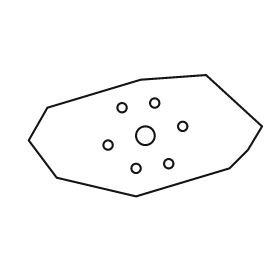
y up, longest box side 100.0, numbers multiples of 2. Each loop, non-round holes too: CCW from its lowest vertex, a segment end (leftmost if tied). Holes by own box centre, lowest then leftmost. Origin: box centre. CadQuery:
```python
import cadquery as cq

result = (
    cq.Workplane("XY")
    .moveTo(-4.0, -26.0)
    .lineTo(36.0, -14.0)
    .lineTo(44.0, -6.0)
    .lineTo(50.0, 4.0)
    .lineTo(26.0, 26.0)
    .lineTo(-2.0, 24.0)
    .lineTo(-42.0, 12.0)
    .lineTo(-50.0, -2.0)
    .lineTo(-38.0, -18.0)
    .close()
    .moveTo(-4.0, -14.0)
    .circle(2.0)
    .moveTo(10.0, -12.0)
    .circle(2.0)
    .moveTo(-16.0, -4.0)
    .circle(2.0)
    .moveTo(0.0, 0.0)
    .circle(4.0)
    .moveTo(16.0, 4.0)
    .circle(2.0)
    .moveTo(-10.0, 12.0)
    .circle(2.0)
    .moveTo(4.0, 14.0)
    .circle(2.0)
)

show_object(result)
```